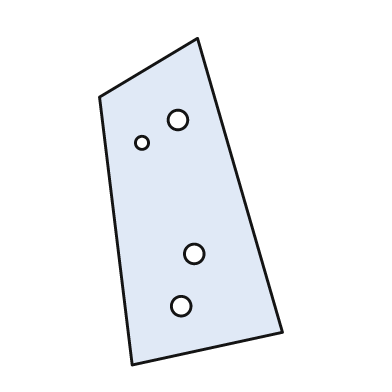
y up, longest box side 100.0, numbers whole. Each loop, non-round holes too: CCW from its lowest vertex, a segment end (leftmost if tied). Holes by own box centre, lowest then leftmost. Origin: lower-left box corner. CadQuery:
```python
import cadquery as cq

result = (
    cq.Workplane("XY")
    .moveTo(10.0, 0.0)
    .lineTo(56.0, 10.0)
    .lineTo(30.0, 100.0)
    .lineTo(0.0, 82.0)
    .close()
    .moveTo(25.0, 18.0)
    .circle(3.0)
    .moveTo(29.0, 34.0)
    .circle(3.0)
    .moveTo(13.0, 68.0)
    .circle(2.0)
    .moveTo(24.0, 75.0)
    .circle(3.0)
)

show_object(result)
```